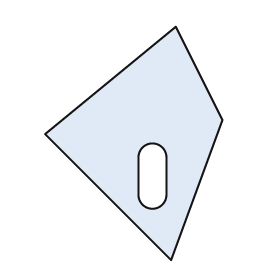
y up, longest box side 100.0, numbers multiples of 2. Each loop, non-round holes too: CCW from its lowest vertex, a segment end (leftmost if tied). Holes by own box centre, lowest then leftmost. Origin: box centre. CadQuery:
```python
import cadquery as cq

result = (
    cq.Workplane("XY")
    .moveTo(16.0, -50.0)
    .lineTo(38.0, 10.0)
    .lineTo(18.0, 50.0)
    .lineTo(-38.0, 4.0)
    .close()
    .moveTo(2.0, -22.0)
    .threePointArc((8.0, -28.0), (14.0, -22.0))
    .lineTo(14.0, -6.0)
    .threePointArc((8.0, 0.0), (2.0, -6.0))
    .close()
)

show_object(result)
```